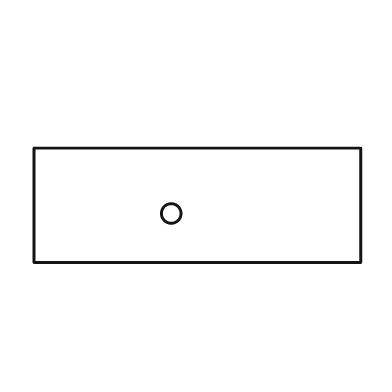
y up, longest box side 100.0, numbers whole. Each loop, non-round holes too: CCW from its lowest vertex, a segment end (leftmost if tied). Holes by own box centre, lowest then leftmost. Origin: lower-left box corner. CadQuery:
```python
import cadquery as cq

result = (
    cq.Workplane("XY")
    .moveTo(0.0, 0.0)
    .lineTo(100.0, 0.0)
    .lineTo(100.0, 35.0)
    .lineTo(0.0, 35.0)
    .close()
    .moveTo(42.0, 15.0)
    .circle(3.0)
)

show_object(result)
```